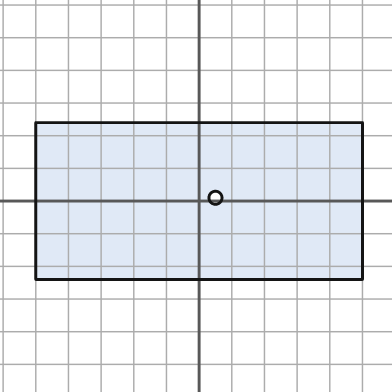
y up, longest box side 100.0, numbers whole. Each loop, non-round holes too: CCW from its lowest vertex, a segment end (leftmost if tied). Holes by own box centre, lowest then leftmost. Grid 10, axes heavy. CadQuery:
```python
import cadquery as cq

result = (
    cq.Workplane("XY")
    .moveTo(-50.0, -24.0)
    .lineTo(50.0, -24.0)
    .lineTo(50.0, 24.0)
    .lineTo(-50.0, 24.0)
    .close()
    .moveTo(5.0, 1.0)
    .circle(2.0)
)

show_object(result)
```